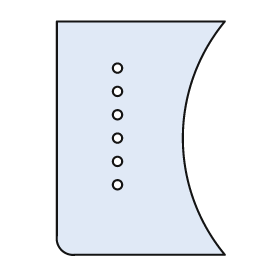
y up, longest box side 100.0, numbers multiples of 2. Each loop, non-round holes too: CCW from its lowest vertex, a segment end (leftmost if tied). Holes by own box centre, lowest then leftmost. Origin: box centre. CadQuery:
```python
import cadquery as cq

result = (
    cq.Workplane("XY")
    .moveTo(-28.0, -50.0)
    .lineTo(36.0, -50.0)
    .threePointArc((18.0, 0.0), (36.0, 50.0))
    .lineTo(-36.0, 50.0)
    .lineTo(-36.0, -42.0)
    .threePointArc((-34.0, -48.0), (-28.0, -50.0))
    .close()
    .moveTo(-10.0, -20.0)
    .circle(2.0)
    .moveTo(-10.0, -10.0)
    .circle(2.0)
    .moveTo(-10.0, 0.0)
    .circle(2.0)
    .moveTo(-10.0, 10.0)
    .circle(2.0)
    .moveTo(-10.0, 20.0)
    .circle(2.0)
    .moveTo(-10.0, 30.0)
    .circle(2.0)
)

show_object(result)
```